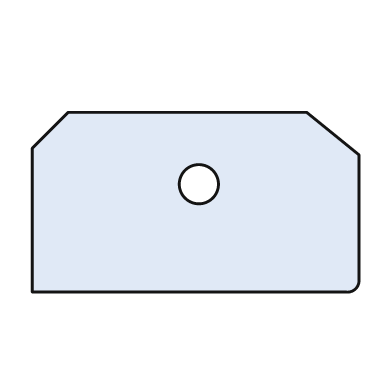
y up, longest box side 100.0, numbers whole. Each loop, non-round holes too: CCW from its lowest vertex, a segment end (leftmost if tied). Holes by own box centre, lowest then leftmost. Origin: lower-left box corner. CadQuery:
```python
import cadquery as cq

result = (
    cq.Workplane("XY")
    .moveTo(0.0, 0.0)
    .lineTo(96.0, 0.0)
    .threePointArc((99.0, 1.0), (100.0, 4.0))
    .lineTo(100.0, 42.0)
    .lineTo(84.0, 55.0)
    .lineTo(11.0, 55.0)
    .lineTo(0.0, 44.0)
    .close()
    .moveTo(51.0, 33.0)
    .circle(6.0)
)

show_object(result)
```